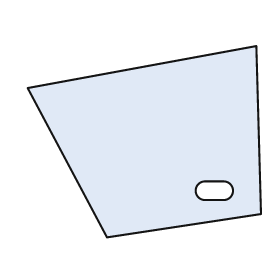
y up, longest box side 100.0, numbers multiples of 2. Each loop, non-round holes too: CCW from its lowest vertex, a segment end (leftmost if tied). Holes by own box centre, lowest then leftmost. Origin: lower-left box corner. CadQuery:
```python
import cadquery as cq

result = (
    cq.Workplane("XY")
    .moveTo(34.0, 0.0)
    .lineTo(100.0, 10.0)
    .lineTo(98.0, 82.0)
    .lineTo(0.0, 64.0)
    .close()
    .moveTo(76.0, 16.0)
    .lineTo(84.0, 16.0)
    .threePointArc((88.0, 20.0), (84.0, 24.0))
    .lineTo(76.0, 24.0)
    .threePointArc((72.0, 20.0), (76.0, 16.0))
    .close()
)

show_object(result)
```